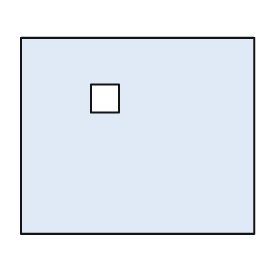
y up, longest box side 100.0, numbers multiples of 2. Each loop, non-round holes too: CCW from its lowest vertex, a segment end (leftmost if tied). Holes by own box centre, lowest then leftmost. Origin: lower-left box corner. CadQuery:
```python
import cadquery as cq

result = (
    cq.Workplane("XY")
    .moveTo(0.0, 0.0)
    .lineTo(100.0, 0.0)
    .lineTo(100.0, 84.0)
    .lineTo(0.0, 84.0)
    .close()
    .moveTo(30.0, 52.0)
    .lineTo(42.0, 52.0)
    .lineTo(42.0, 64.0)
    .lineTo(30.0, 64.0)
    .close()
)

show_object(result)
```